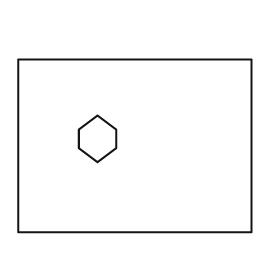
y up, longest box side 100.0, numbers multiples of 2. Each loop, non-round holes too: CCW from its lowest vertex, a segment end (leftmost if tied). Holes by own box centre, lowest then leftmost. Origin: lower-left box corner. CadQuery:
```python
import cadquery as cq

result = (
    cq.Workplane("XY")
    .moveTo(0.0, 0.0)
    .lineTo(100.0, 0.0)
    .lineTo(100.0, 74.0)
    .lineTo(0.0, 74.0)
    .close()
    .moveTo(34.0, 30.0)
    .lineTo(42.0, 36.0)
    .lineTo(42.0, 44.0)
    .lineTo(34.0, 50.0)
    .lineTo(26.0, 44.0)
    .lineTo(26.0, 36.0)
    .close()
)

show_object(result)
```